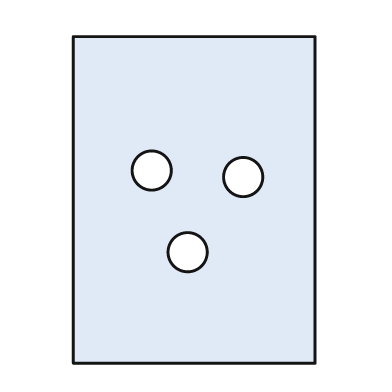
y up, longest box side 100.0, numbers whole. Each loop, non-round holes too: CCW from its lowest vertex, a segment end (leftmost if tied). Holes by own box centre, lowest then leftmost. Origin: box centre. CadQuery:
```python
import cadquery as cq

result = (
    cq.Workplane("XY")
    .moveTo(-37.0, -50.0)
    .lineTo(37.0, -50.0)
    .lineTo(37.0, 50.0)
    .lineTo(-37.0, 50.0)
    .close()
    .moveTo(-2.0, -16.0)
    .circle(6.0)
    .moveTo(15.0, 7.0)
    .circle(6.0)
    .moveTo(-13.0, 9.0)
    .circle(6.0)
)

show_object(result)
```